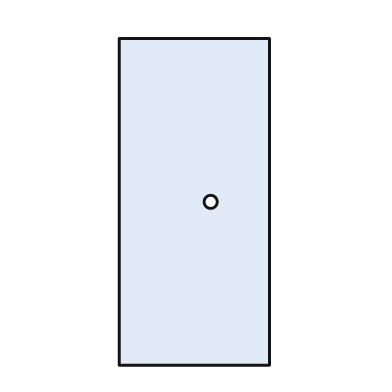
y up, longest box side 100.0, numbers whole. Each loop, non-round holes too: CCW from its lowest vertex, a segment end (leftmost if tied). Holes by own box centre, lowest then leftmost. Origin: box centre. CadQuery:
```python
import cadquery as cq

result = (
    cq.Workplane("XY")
    .moveTo(-23.0, -50.0)
    .lineTo(23.0, -50.0)
    .lineTo(23.0, 50.0)
    .lineTo(-23.0, 50.0)
    .close()
    .moveTo(5.0, 0.0)
    .circle(2.0)
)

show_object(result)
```